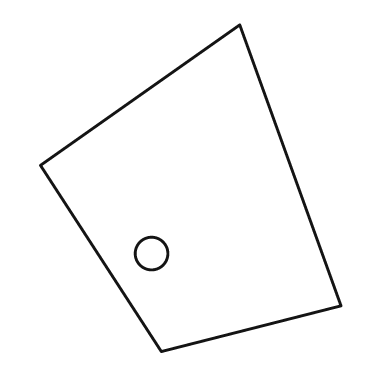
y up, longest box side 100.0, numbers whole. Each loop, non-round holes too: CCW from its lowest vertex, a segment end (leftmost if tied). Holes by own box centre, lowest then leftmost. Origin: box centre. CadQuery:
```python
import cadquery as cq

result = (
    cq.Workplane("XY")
    .moveTo(-9.0, -50.0)
    .lineTo(46.0, -36.0)
    .lineTo(15.0, 50.0)
    .lineTo(-46.0, 7.0)
    .close()
    .moveTo(-12.0, -20.0)
    .circle(5.0)
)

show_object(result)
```